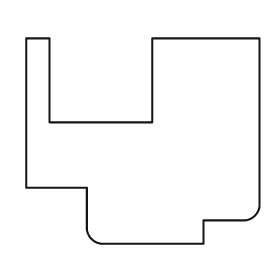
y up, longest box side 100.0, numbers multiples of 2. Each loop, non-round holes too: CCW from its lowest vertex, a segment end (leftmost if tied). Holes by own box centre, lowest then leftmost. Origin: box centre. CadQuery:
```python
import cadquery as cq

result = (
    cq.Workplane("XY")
    .moveTo(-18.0, -44.0)
    .lineTo(26.0, -44.0)
    .lineTo(26.0, -34.0)
    .lineTo(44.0, -34.0)
    .threePointArc((48.0, -32.0), (50.0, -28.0))
    .lineTo(50.0, 44.0)
    .lineTo(4.0, 44.0)
    .lineTo(4.0, 8.0)
    .lineTo(-40.0, 8.0)
    .lineTo(-40.0, 44.0)
    .lineTo(-50.0, 44.0)
    .lineTo(-50.0, -20.0)
    .lineTo(-24.0, -20.0)
    .lineTo(-24.0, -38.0)
    .threePointArc((-22.0, -42.0), (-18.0, -44.0))
    .close()
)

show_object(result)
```